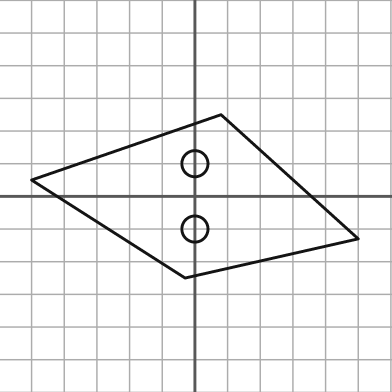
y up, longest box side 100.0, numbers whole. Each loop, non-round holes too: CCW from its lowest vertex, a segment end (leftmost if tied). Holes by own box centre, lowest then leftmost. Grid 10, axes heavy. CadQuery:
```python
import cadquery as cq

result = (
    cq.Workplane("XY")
    .moveTo(-3.0, -25.0)
    .lineTo(50.0, -13.0)
    .lineTo(8.0, 25.0)
    .lineTo(-50.0, 5.0)
    .close()
    .moveTo(0.0, -10.0)
    .circle(4.0)
    .moveTo(0.0, 10.0)
    .circle(4.0)
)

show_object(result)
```